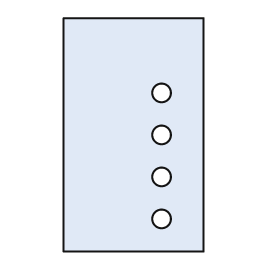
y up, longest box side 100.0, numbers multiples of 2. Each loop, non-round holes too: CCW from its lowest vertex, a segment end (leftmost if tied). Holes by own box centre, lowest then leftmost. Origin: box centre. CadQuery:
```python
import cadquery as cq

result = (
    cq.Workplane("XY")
    .moveTo(-30.0, -50.0)
    .lineTo(30.0, -50.0)
    .lineTo(30.0, 50.0)
    .lineTo(-30.0, 50.0)
    .close()
    .moveTo(12.0, -36.0)
    .circle(4.0)
    .moveTo(12.0, -18.0)
    .circle(4.0)
    .moveTo(12.0, 0.0)
    .circle(4.0)
    .moveTo(12.0, 18.0)
    .circle(4.0)
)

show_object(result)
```